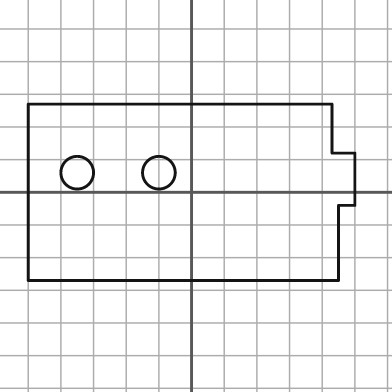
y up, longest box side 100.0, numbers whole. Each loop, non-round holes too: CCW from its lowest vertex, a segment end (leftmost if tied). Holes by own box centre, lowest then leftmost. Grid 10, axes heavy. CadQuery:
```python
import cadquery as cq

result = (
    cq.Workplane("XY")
    .moveTo(-50.0, -27.0)
    .lineTo(45.0, -27.0)
    .lineTo(45.0, -4.0)
    .lineTo(50.0, -4.0)
    .lineTo(50.0, 12.0)
    .lineTo(43.0, 12.0)
    .lineTo(43.0, 27.0)
    .lineTo(-50.0, 27.0)
    .close()
    .moveTo(-35.0, 6.0)
    .circle(5.0)
    .moveTo(-10.0, 6.0)
    .circle(5.0)
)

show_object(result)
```